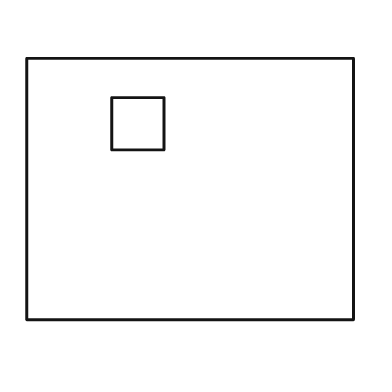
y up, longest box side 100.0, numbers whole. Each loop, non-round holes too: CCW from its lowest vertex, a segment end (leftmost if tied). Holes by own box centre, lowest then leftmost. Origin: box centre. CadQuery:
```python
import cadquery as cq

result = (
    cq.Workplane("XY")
    .moveTo(-50.0, -40.0)
    .lineTo(50.0, -40.0)
    .lineTo(50.0, 40.0)
    .lineTo(-50.0, 40.0)
    .close()
    .moveTo(-24.0, 12.0)
    .lineTo(-8.0, 12.0)
    .lineTo(-8.0, 28.0)
    .lineTo(-24.0, 28.0)
    .close()
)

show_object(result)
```